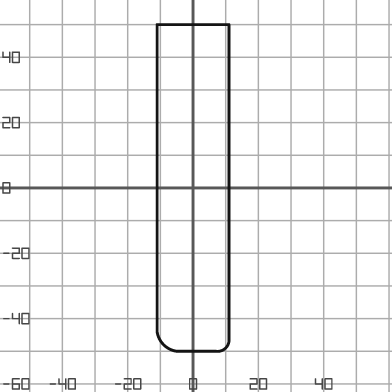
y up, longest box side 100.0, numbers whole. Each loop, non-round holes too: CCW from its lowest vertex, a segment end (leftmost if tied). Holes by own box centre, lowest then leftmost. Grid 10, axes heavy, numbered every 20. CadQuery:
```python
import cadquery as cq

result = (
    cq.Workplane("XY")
    .moveTo(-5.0, -50.0)
    .lineTo(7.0, -50.0)
    .threePointArc((10.0, -49.0), (11.0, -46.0))
    .lineTo(11.0, 50.0)
    .lineTo(-11.0, 50.0)
    .lineTo(-11.0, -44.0)
    .threePointArc((-9.0, -48.0), (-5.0, -50.0))
    .close()
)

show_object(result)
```